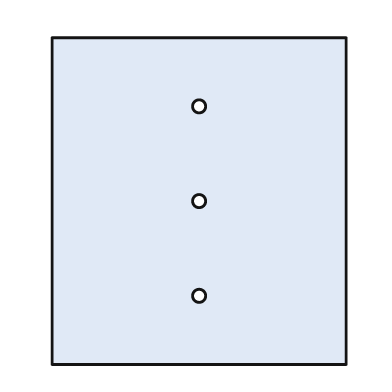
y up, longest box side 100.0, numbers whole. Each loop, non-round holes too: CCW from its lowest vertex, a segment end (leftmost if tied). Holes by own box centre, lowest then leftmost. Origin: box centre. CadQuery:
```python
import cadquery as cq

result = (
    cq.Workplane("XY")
    .moveTo(-45.0, -50.0)
    .lineTo(45.0, -50.0)
    .lineTo(45.0, 50.0)
    .lineTo(-45.0, 50.0)
    .close()
    .moveTo(0.0, -29.0)
    .circle(2.0)
    .moveTo(0.0, 0.0)
    .circle(2.0)
    .moveTo(0.0, 29.0)
    .circle(2.0)
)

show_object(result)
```